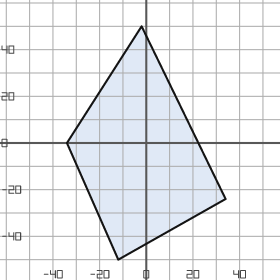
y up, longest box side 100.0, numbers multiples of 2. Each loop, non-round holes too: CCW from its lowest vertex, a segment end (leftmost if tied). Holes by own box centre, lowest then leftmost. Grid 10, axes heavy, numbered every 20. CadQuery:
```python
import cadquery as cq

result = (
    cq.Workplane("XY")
    .moveTo(-12.0, -50.0)
    .lineTo(34.0, -24.0)
    .lineTo(-2.0, 50.0)
    .lineTo(-34.0, 0.0)
    .close()
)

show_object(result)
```